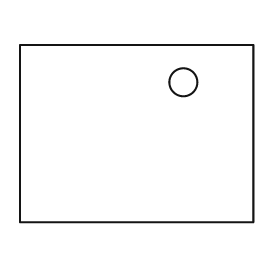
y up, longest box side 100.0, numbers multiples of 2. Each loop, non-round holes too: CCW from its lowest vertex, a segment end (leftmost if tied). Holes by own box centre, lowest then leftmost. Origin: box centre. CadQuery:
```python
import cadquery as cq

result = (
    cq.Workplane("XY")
    .moveTo(-50.0, -38.0)
    .lineTo(50.0, -38.0)
    .lineTo(50.0, 38.0)
    .lineTo(-50.0, 38.0)
    .close()
    .moveTo(20.0, 22.0)
    .circle(6.0)
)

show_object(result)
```